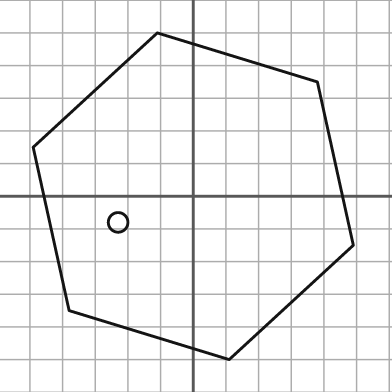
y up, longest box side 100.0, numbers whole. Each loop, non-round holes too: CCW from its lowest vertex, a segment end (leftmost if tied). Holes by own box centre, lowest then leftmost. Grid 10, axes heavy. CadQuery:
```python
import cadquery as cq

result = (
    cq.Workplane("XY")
    .moveTo(11.0, -50.0)
    .lineTo(49.0, -15.0)
    .lineTo(38.0, 35.0)
    .lineTo(-11.0, 50.0)
    .lineTo(-49.0, 15.0)
    .lineTo(-38.0, -35.0)
    .close()
    .moveTo(-23.0, -8.0)
    .circle(3.0)
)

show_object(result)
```